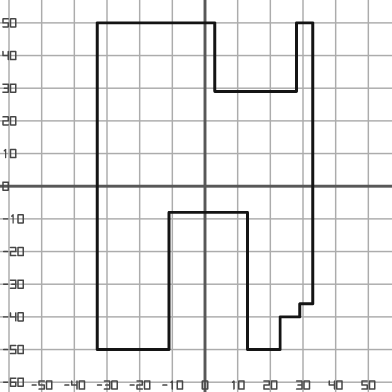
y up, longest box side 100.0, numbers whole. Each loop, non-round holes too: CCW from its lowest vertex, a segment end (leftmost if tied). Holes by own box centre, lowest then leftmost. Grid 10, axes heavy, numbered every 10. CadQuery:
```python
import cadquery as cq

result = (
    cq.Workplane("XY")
    .moveTo(-33.0, -50.0)
    .lineTo(-11.0, -50.0)
    .lineTo(-11.0, -8.0)
    .lineTo(13.0, -8.0)
    .lineTo(13.0, -50.0)
    .lineTo(23.0, -50.0)
    .lineTo(23.0, -40.0)
    .lineTo(29.0, -40.0)
    .lineTo(29.0, -36.0)
    .lineTo(33.0, -36.0)
    .lineTo(33.0, 50.0)
    .lineTo(28.0, 50.0)
    .lineTo(28.0, 29.0)
    .lineTo(3.0, 29.0)
    .lineTo(3.0, 50.0)
    .lineTo(-33.0, 50.0)
    .close()
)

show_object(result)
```